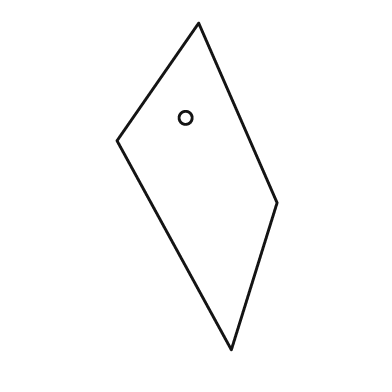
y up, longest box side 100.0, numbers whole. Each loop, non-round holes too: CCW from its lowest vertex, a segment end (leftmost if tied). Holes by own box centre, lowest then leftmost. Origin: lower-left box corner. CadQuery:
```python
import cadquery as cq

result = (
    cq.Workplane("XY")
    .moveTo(35.0, 0.0)
    .lineTo(49.0, 45.0)
    .lineTo(25.0, 100.0)
    .lineTo(0.0, 64.0)
    .close()
    .moveTo(21.0, 71.0)
    .circle(2.0)
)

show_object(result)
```